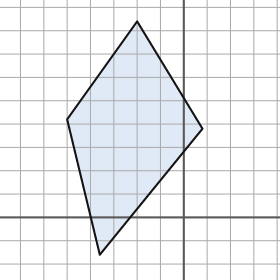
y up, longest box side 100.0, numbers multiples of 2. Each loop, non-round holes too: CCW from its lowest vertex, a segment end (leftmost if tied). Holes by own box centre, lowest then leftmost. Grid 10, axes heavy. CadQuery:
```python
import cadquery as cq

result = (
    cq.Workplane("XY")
    .moveTo(-36.0, -16.0)
    .lineTo(8.0, 38.0)
    .lineTo(-20.0, 84.0)
    .lineTo(-50.0, 42.0)
    .close()
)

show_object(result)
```